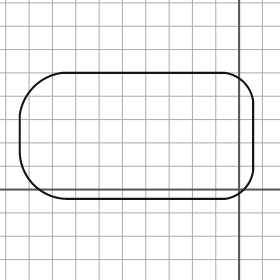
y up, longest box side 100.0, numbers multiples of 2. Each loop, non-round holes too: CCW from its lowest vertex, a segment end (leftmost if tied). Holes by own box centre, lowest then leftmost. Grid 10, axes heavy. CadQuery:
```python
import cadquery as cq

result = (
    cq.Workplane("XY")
    .moveTo(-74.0, -4.0)
    .lineTo(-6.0, -4.0)
    .threePointArc((2.0, 0.0), (6.0, 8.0))
    .lineTo(6.0, 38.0)
    .threePointArc((2.0, 46.0), (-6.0, 50.0))
    .lineTo(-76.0, 50.0)
    .threePointArc((-88.0, 44.0), (-94.0, 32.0))
    .lineTo(-94.0, 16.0)
    .threePointArc((-88.0, 2.0), (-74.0, -4.0))
    .close()
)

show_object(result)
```